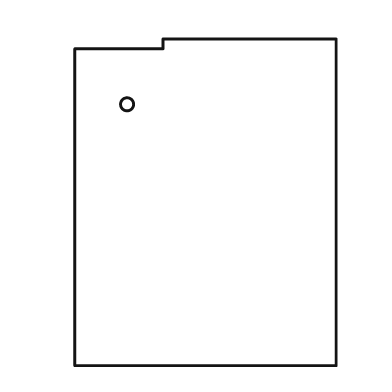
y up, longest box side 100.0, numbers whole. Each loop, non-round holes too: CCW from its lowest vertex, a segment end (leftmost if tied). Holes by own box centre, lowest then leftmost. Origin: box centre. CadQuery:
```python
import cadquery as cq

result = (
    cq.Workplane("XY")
    .moveTo(-40.0, -50.0)
    .lineTo(40.0, -50.0)
    .lineTo(40.0, 50.0)
    .lineTo(-13.0, 50.0)
    .lineTo(-13.0, 47.0)
    .lineTo(-40.0, 47.0)
    .close()
    .moveTo(-24.0, 30.0)
    .circle(2.0)
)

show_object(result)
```